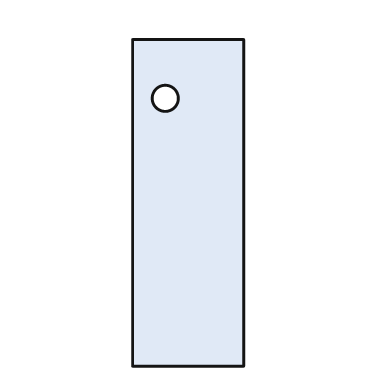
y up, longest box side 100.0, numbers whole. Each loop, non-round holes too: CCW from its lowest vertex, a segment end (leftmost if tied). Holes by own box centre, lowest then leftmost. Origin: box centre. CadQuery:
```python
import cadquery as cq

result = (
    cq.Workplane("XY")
    .moveTo(-17.0, -50.0)
    .lineTo(17.0, -50.0)
    .lineTo(17.0, 50.0)
    .lineTo(-17.0, 50.0)
    .close()
    .moveTo(-7.0, 32.0)
    .circle(4.0)
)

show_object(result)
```